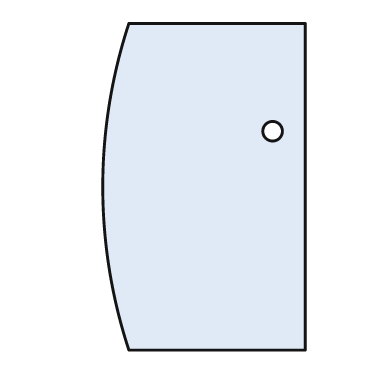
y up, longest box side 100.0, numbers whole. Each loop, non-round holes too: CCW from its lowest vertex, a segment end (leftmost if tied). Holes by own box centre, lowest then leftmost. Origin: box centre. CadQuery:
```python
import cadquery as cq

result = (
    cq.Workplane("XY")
    .moveTo(-23.0, -50.0)
    .lineTo(31.0, -50.0)
    .lineTo(31.0, 50.0)
    .lineTo(-23.0, 50.0)
    .threePointArc((-31.0, 0.0), (-23.0, -50.0))
    .close()
    .moveTo(21.0, 17.0)
    .circle(3.0)
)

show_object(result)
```